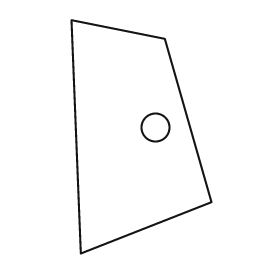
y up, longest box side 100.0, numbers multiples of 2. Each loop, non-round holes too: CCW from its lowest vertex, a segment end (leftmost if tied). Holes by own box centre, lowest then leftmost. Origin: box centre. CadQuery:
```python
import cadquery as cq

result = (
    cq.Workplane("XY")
    .moveTo(-26.0, -50.0)
    .lineTo(30.0, -28.0)
    .lineTo(10.0, 42.0)
    .lineTo(-30.0, 50.0)
    .close()
    .moveTo(6.0, 4.0)
    .circle(6.0)
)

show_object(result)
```